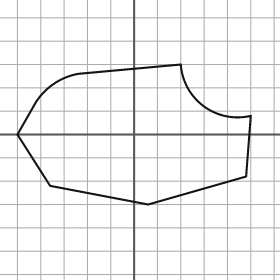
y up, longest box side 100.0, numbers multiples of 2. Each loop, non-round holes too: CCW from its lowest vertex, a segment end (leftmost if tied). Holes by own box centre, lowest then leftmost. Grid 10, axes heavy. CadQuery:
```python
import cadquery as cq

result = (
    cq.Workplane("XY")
    .moveTo(6.0, -30.0)
    .lineTo(48.0, -18.0)
    .lineTo(50.0, 8.0)
    .threePointArc((30.0, 12.0), (20.0, 30.0))
    .lineTo(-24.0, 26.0)
    .threePointArc((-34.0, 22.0), (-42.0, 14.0))
    .lineTo(-50.0, 0.0)
    .lineTo(-36.0, -22.0)
    .close()
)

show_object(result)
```